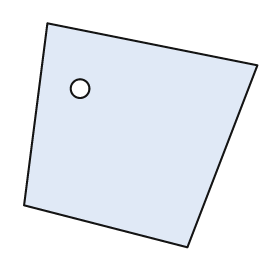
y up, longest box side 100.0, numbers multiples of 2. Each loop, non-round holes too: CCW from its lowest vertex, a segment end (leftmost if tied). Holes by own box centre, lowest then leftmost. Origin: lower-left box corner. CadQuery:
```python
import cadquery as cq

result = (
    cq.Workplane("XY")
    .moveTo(70.0, 0.0)
    .lineTo(100.0, 78.0)
    .lineTo(10.0, 96.0)
    .lineTo(0.0, 18.0)
    .close()
    .moveTo(24.0, 68.0)
    .circle(4.0)
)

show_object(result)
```